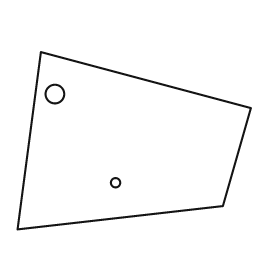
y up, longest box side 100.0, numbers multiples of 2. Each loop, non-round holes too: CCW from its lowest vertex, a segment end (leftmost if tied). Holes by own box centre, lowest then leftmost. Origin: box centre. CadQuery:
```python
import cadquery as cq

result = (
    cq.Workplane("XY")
    .moveTo(-50.0, -38.0)
    .lineTo(38.0, -28.0)
    .lineTo(50.0, 14.0)
    .lineTo(-40.0, 38.0)
    .close()
    .moveTo(-8.0, -18.0)
    .circle(2.0)
    .moveTo(-34.0, 20.0)
    .circle(4.0)
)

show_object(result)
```